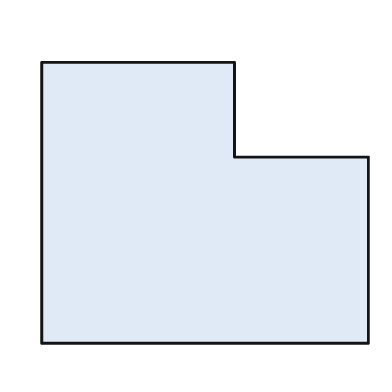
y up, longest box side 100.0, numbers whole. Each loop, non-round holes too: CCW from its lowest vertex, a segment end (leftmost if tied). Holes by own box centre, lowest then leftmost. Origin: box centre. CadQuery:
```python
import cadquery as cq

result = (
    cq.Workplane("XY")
    .moveTo(-50.0, -43.0)
    .lineTo(50.0, -43.0)
    .lineTo(50.0, 14.0)
    .lineTo(9.0, 14.0)
    .lineTo(9.0, 43.0)
    .lineTo(-50.0, 43.0)
    .close()
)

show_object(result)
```